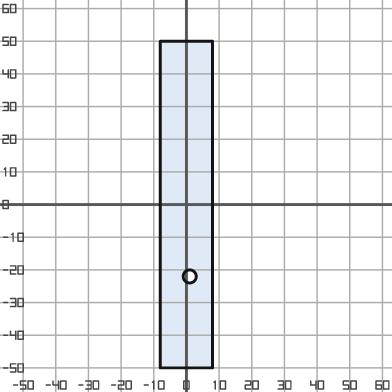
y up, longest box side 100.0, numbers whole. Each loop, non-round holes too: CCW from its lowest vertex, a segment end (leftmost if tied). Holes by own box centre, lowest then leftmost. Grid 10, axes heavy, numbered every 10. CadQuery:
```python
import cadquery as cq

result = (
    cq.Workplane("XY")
    .moveTo(-8.0, -50.0)
    .lineTo(8.0, -50.0)
    .lineTo(8.0, 50.0)
    .lineTo(-8.0, 50.0)
    .close()
    .moveTo(1.0, -22.0)
    .circle(2.0)
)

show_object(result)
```